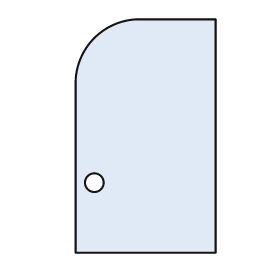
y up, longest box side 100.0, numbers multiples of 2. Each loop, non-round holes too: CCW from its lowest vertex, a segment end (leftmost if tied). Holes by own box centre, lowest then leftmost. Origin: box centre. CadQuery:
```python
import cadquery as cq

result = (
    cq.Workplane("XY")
    .moveTo(-30.0, -50.0)
    .lineTo(30.0, -50.0)
    .lineTo(30.0, 50.0)
    .lineTo(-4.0, 50.0)
    .threePointArc((-22.0, 42.0), (-30.0, 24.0))
    .close()
    .moveTo(-22.0, -20.0)
    .circle(4.0)
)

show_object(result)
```